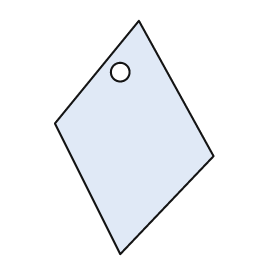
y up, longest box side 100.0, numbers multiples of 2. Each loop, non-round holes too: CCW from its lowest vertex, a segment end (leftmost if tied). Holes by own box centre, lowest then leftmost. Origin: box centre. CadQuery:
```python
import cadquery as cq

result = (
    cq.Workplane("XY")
    .moveTo(-6.0, -50.0)
    .lineTo(34.0, -8.0)
    .lineTo(2.0, 50.0)
    .lineTo(-34.0, 6.0)
    .close()
    .moveTo(-6.0, 28.0)
    .circle(4.0)
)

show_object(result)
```